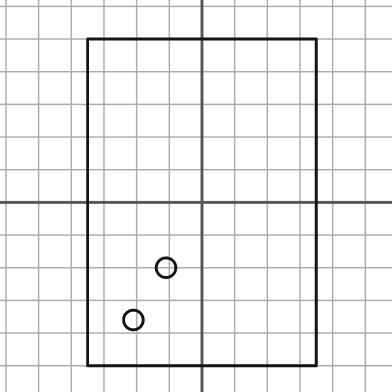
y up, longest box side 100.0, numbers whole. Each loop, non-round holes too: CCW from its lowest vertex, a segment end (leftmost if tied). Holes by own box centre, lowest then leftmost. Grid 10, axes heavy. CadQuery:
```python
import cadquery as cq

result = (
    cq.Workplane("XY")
    .moveTo(-35.0, -50.0)
    .lineTo(35.0, -50.0)
    .lineTo(35.0, 50.0)
    .lineTo(-35.0, 50.0)
    .close()
    .moveTo(-21.0, -36.0)
    .circle(3.0)
    .moveTo(-11.0, -20.0)
    .circle(3.0)
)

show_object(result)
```